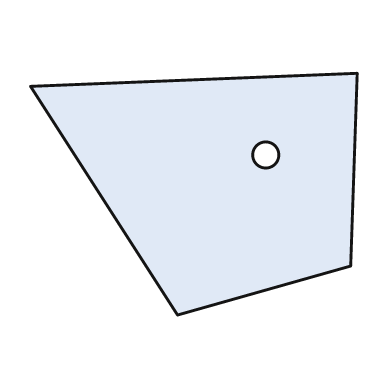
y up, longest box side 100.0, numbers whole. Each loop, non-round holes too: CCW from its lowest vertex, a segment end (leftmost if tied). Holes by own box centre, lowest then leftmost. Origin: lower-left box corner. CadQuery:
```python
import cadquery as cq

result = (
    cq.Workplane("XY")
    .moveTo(45.0, 0.0)
    .lineTo(98.0, 15.0)
    .lineTo(100.0, 74.0)
    .lineTo(0.0, 70.0)
    .close()
    .moveTo(72.0, 49.0)
    .circle(4.0)
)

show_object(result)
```